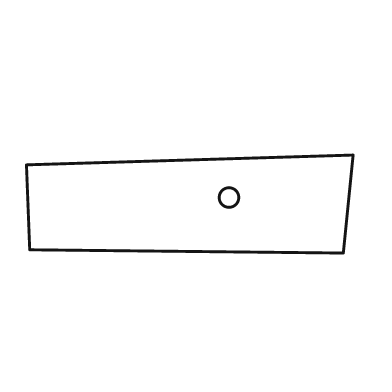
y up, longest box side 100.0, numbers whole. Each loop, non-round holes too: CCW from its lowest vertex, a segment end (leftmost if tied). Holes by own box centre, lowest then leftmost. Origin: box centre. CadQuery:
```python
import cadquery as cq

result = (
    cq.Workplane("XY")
    .moveTo(47.0, -15.0)
    .lineTo(50.0, 15.0)
    .lineTo(-50.0, 12.0)
    .lineTo(-49.0, -14.0)
    .close()
    .moveTo(12.0, 2.0)
    .circle(3.0)
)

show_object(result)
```